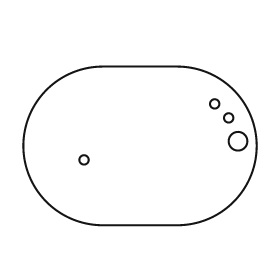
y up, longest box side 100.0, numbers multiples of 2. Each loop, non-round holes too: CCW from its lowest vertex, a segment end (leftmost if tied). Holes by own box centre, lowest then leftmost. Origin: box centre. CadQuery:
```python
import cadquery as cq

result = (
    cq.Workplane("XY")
    .moveTo(-16.0, -34.0)
    .lineTo(16.0, -34.0)
    .threePointArc((50.0, 0.0), (16.0, 34.0))
    .lineTo(-16.0, 34.0)
    .threePointArc((-50.0, 0.0), (-16.0, -34.0))
    .close()
    .moveTo(-24.0, -6.0)
    .circle(2.0)
    .moveTo(42.0, 2.0)
    .circle(4.0)
    .moveTo(38.0, 12.0)
    .circle(2.0)
    .moveTo(32.0, 18.0)
    .circle(2.0)
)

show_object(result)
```